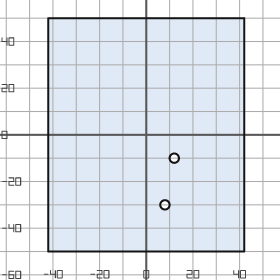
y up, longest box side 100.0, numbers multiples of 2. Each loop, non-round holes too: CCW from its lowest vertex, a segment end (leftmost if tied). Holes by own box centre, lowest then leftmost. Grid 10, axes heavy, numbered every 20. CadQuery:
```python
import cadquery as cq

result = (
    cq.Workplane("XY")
    .moveTo(-42.0, -50.0)
    .lineTo(42.0, -50.0)
    .lineTo(42.0, 50.0)
    .lineTo(-42.0, 50.0)
    .close()
    .moveTo(8.0, -30.0)
    .circle(2.0)
    .moveTo(12.0, -10.0)
    .circle(2.0)
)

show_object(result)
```